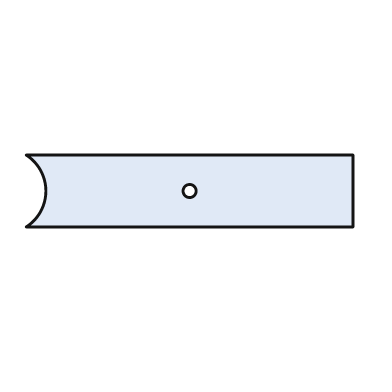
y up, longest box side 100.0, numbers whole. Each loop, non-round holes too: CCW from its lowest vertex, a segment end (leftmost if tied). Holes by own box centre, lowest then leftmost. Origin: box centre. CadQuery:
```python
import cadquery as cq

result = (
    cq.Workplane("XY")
    .moveTo(-50.0, -11.0)
    .lineTo(50.0, -11.0)
    .lineTo(50.0, 11.0)
    .lineTo(-50.0, 11.0)
    .threePointArc((-44.0, 0.0), (-50.0, -11.0))
    .close()
    .moveTo(0.0, 0.0)
    .circle(2.0)
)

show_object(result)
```